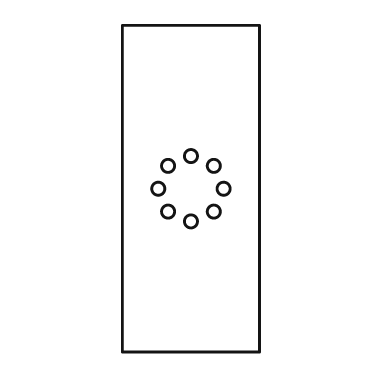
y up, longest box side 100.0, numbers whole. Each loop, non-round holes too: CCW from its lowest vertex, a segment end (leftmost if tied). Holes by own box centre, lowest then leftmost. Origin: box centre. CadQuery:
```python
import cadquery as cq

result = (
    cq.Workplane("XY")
    .moveTo(-21.0, -50.0)
    .lineTo(21.0, -50.0)
    .lineTo(21.0, 50.0)
    .lineTo(-21.0, 50.0)
    .close()
    .moveTo(0.0, -10.0)
    .circle(2.0)
    .moveTo(-7.0, -7.0)
    .circle(2.0)
    .moveTo(7.0, -7.0)
    .circle(2.0)
    .moveTo(-10.0, 0.0)
    .circle(2.0)
    .moveTo(10.0, 0.0)
    .circle(2.0)
    .moveTo(-7.0, 7.0)
    .circle(2.0)
    .moveTo(7.0, 7.0)
    .circle(2.0)
    .moveTo(0.0, 10.0)
    .circle(2.0)
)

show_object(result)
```